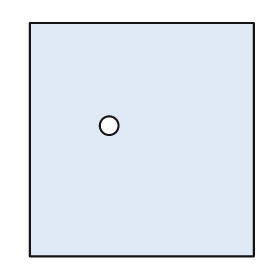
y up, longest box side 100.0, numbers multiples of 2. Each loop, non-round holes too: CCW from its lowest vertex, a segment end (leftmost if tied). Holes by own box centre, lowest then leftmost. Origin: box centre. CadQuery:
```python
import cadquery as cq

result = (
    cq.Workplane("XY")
    .moveTo(-48.0, -50.0)
    .lineTo(48.0, -50.0)
    .lineTo(48.0, 50.0)
    .lineTo(-48.0, 50.0)
    .close()
    .moveTo(-14.0, 6.0)
    .circle(4.0)
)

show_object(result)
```